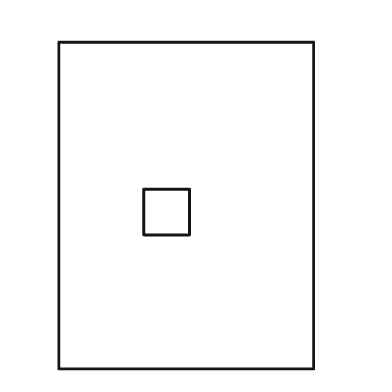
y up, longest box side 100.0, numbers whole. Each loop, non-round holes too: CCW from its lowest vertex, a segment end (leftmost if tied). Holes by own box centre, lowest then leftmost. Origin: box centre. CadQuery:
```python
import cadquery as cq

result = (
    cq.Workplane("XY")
    .moveTo(-39.0, -50.0)
    .lineTo(39.0, -50.0)
    .lineTo(39.0, 50.0)
    .lineTo(-39.0, 50.0)
    .close()
    .moveTo(-13.0, -9.0)
    .lineTo(1.0, -9.0)
    .lineTo(1.0, 5.0)
    .lineTo(-13.0, 5.0)
    .close()
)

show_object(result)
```